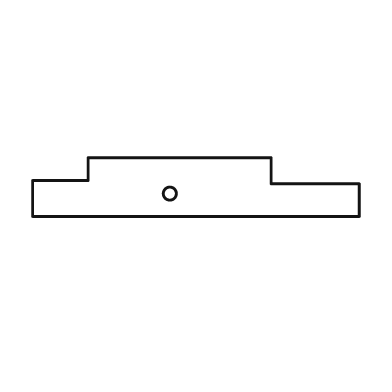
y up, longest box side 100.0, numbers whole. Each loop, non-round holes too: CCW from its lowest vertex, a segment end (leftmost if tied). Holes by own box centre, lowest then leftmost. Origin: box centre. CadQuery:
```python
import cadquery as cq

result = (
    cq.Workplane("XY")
    .moveTo(-50.0, -9.0)
    .lineTo(50.0, -9.0)
    .lineTo(50.0, 1.0)
    .lineTo(23.0, 1.0)
    .lineTo(23.0, 9.0)
    .lineTo(-33.0, 9.0)
    .lineTo(-33.0, 2.0)
    .lineTo(-50.0, 2.0)
    .close()
    .moveTo(-8.0, -2.0)
    .circle(2.0)
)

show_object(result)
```